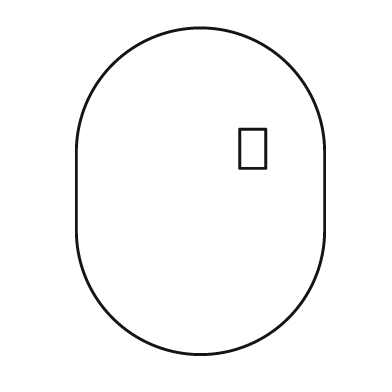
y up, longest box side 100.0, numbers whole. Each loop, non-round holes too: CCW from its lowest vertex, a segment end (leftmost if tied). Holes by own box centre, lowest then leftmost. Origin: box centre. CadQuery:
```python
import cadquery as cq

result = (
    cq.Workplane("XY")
    .moveTo(-38.0, -12.0)
    .threePointArc((0.0, -50.0), (38.0, -12.0))
    .lineTo(38.0, 12.0)
    .threePointArc((0.0, 50.0), (-38.0, 12.0))
    .close()
    .moveTo(12.0, 7.0)
    .lineTo(20.0, 7.0)
    .lineTo(20.0, 19.0)
    .lineTo(12.0, 19.0)
    .close()
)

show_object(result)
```